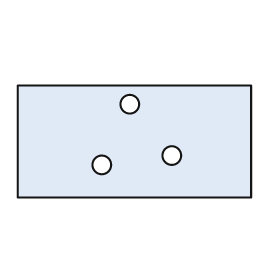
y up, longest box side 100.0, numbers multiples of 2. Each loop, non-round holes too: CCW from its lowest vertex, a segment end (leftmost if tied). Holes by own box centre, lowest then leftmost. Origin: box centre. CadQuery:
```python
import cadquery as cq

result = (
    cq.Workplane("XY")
    .moveTo(-50.0, -24.0)
    .lineTo(50.0, -24.0)
    .lineTo(50.0, 24.0)
    .lineTo(-50.0, 24.0)
    .close()
    .moveTo(-14.0, -10.0)
    .circle(4.0)
    .moveTo(16.0, -6.0)
    .circle(4.0)
    .moveTo(-2.0, 16.0)
    .circle(4.0)
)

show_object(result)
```